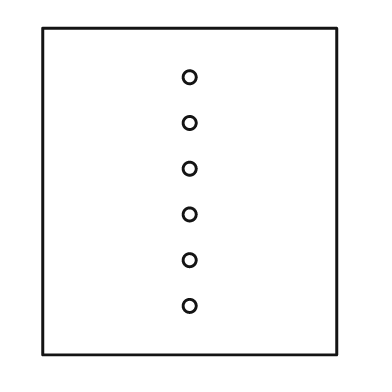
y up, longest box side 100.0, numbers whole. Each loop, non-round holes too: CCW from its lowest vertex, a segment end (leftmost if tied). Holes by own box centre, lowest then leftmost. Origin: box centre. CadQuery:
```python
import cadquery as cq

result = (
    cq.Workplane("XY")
    .moveTo(-45.0, -50.0)
    .lineTo(45.0, -50.0)
    .lineTo(45.0, 50.0)
    .lineTo(-45.0, 50.0)
    .close()
    .moveTo(0.0, -35.0)
    .circle(2.0)
    .moveTo(0.0, -21.0)
    .circle(2.0)
    .moveTo(0.0, -7.0)
    .circle(2.0)
    .moveTo(0.0, 7.0)
    .circle(2.0)
    .moveTo(0.0, 21.0)
    .circle(2.0)
    .moveTo(0.0, 35.0)
    .circle(2.0)
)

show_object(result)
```